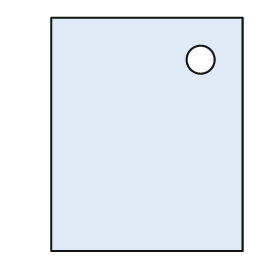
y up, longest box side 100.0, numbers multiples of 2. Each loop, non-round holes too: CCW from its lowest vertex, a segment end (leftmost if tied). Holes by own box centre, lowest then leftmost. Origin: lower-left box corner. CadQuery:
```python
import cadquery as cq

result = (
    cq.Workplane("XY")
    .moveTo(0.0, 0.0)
    .lineTo(82.0, 0.0)
    .lineTo(82.0, 100.0)
    .lineTo(0.0, 100.0)
    .close()
    .moveTo(64.0, 82.0)
    .circle(6.0)
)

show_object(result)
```